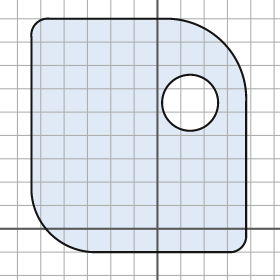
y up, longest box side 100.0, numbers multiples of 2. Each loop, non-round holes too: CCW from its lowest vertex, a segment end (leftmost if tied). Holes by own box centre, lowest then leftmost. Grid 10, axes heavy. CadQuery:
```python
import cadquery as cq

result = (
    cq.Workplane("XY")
    .moveTo(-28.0, -10.0)
    .lineTo(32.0, -10.0)
    .threePointArc((36.0, -8.0), (38.0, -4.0))
    .lineTo(38.0, 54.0)
    .threePointArc((28.0, 80.0), (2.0, 90.0))
    .lineTo(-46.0, 90.0)
    .threePointArc((-52.0, 88.0), (-54.0, 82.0))
    .lineTo(-54.0, 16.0)
    .threePointArc((-46.0, -2.0), (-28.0, -10.0))
    .close()
    .moveTo(14.0, 54.0)
    .circle(12.0)
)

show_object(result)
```